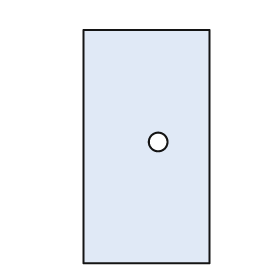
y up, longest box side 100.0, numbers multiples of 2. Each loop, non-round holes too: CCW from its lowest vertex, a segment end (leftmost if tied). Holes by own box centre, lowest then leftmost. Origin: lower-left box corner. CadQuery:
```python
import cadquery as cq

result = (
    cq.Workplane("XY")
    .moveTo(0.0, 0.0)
    .lineTo(54.0, 0.0)
    .lineTo(54.0, 100.0)
    .lineTo(0.0, 100.0)
    .close()
    .moveTo(32.0, 52.0)
    .circle(4.0)
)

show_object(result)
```